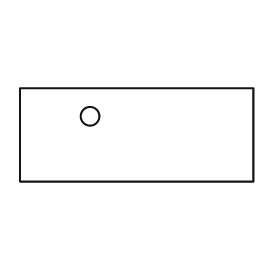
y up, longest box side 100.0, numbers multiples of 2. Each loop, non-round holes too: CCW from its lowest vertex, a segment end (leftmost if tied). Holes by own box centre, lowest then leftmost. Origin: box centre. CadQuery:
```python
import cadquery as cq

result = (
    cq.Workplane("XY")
    .moveTo(-50.0, -20.0)
    .lineTo(50.0, -20.0)
    .lineTo(50.0, 20.0)
    .lineTo(-50.0, 20.0)
    .close()
    .moveTo(-20.0, 8.0)
    .circle(4.0)
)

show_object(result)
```